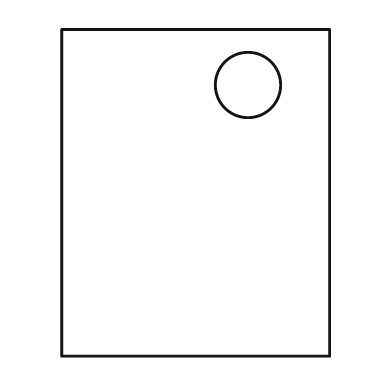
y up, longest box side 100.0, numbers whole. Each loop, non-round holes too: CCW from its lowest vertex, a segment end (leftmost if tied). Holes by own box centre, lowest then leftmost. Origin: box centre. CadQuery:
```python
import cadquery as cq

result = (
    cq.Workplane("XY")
    .moveTo(-41.0, -50.0)
    .lineTo(41.0, -50.0)
    .lineTo(41.0, 50.0)
    .lineTo(-41.0, 50.0)
    .close()
    .moveTo(16.0, 33.0)
    .circle(10.0)
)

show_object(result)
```